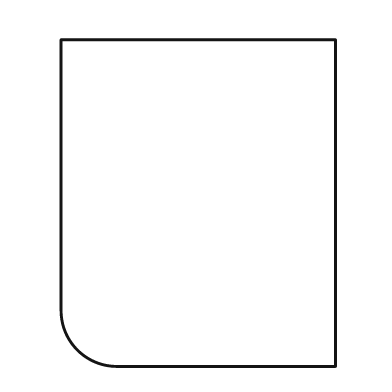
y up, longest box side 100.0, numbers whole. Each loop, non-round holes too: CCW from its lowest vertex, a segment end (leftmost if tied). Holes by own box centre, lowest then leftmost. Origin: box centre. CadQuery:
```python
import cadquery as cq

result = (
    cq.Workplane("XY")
    .moveTo(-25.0, -50.0)
    .lineTo(42.0, -50.0)
    .lineTo(42.0, 50.0)
    .lineTo(-42.0, 50.0)
    .lineTo(-42.0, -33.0)
    .threePointArc((-37.0, -45.0), (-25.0, -50.0))
    .close()
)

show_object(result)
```